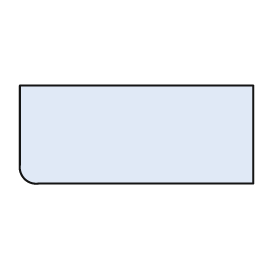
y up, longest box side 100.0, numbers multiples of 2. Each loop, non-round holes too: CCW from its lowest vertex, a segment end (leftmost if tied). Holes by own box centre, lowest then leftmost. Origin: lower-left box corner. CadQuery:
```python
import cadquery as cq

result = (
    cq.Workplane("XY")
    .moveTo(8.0, 0.0)
    .lineTo(100.0, 0.0)
    .lineTo(100.0, 42.0)
    .lineTo(0.0, 42.0)
    .lineTo(0.0, 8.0)
    .threePointArc((2.0, 2.0), (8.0, 0.0))
    .close()
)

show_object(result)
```